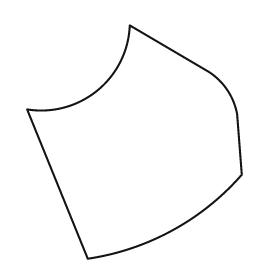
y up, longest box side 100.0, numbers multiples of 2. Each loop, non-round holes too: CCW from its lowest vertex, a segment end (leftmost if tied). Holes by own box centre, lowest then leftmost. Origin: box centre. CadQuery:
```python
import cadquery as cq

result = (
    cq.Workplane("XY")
    .moveTo(-20.0, -50.0)
    .threePointArc((16.0, -38.0), (46.0, -14.0))
    .lineTo(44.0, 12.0)
    .threePointArc((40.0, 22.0), (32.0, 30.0))
    .lineTo(-2.0, 50.0)
    .threePointArc((-16.0, 22.0), (-46.0, 14.0))
    .close()
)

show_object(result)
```